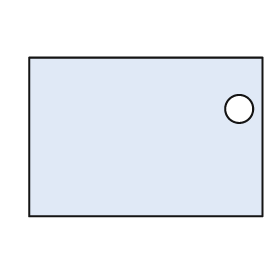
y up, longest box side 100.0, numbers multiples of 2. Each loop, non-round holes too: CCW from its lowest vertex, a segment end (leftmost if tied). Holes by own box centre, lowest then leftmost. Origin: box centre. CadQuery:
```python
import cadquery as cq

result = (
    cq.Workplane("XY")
    .moveTo(-50.0, -34.0)
    .lineTo(50.0, -34.0)
    .lineTo(50.0, 34.0)
    .lineTo(-50.0, 34.0)
    .close()
    .moveTo(40.0, 12.0)
    .circle(6.0)
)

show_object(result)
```